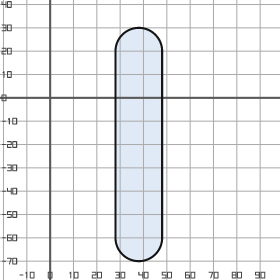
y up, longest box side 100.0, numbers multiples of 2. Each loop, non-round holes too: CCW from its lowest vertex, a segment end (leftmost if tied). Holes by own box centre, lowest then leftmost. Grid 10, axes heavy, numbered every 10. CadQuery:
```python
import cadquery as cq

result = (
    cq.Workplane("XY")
    .moveTo(28.0, -60.0)
    .threePointArc((38.0, -70.0), (48.0, -60.0))
    .lineTo(48.0, 20.0)
    .threePointArc((38.0, 30.0), (28.0, 20.0))
    .close()
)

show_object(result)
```